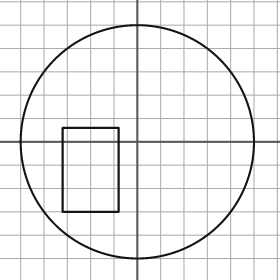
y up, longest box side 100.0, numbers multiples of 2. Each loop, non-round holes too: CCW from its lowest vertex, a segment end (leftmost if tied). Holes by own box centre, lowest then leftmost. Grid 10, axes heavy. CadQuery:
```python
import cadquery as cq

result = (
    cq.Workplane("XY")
    .moveTo(0.0, 0.0)
    .circle(50.0)
    .moveTo(-32.0, -30.0)
    .lineTo(-8.0, -30.0)
    .lineTo(-8.0, 6.0)
    .lineTo(-32.0, 6.0)
    .close()
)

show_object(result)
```